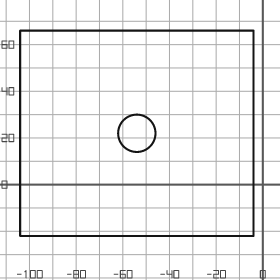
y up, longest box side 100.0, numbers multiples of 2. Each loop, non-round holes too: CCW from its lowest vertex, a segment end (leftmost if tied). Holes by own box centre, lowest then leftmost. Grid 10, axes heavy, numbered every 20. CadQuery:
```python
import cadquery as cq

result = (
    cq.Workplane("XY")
    .moveTo(-104.0, -22.0)
    .lineTo(-4.0, -22.0)
    .lineTo(-4.0, 66.0)
    .lineTo(-104.0, 66.0)
    .close()
    .moveTo(-54.0, 22.0)
    .circle(8.0)
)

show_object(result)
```